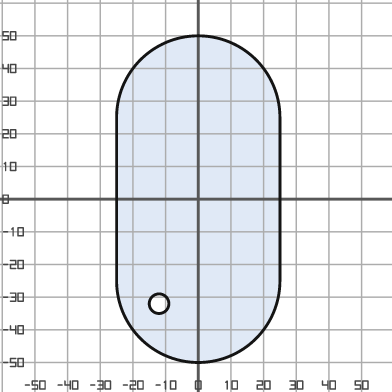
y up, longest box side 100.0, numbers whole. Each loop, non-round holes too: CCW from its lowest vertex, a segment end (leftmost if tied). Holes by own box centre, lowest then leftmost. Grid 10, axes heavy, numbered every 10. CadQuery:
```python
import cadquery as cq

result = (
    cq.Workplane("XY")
    .moveTo(-25.0, -25.0)
    .threePointArc((0.0, -50.0), (25.0, -25.0))
    .lineTo(25.0, 25.0)
    .threePointArc((0.0, 50.0), (-25.0, 25.0))
    .close()
    .moveTo(-12.0, -32.0)
    .circle(3.0)
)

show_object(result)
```